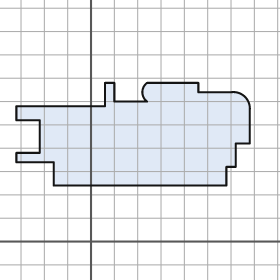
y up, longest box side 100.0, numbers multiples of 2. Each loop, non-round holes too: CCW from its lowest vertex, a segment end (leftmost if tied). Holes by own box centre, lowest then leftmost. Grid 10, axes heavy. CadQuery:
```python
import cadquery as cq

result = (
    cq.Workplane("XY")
    .moveTo(-16.0, 24.0)
    .lineTo(58.0, 24.0)
    .lineTo(58.0, 32.0)
    .lineTo(62.0, 32.0)
    .lineTo(62.0, 42.0)
    .lineTo(68.0, 42.0)
    .lineTo(68.0, 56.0)
    .threePointArc((66.0, 62.0), (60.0, 64.0))
    .lineTo(46.0, 64.0)
    .lineTo(46.0, 68.0)
    .lineTo(24.0, 68.0)
    .threePointArc((22.0, 64.0), (24.0, 60.0))
    .lineTo(10.0, 60.0)
    .lineTo(10.0, 68.0)
    .lineTo(6.0, 68.0)
    .lineTo(6.0, 58.0)
    .lineTo(-32.0, 58.0)
    .lineTo(-32.0, 52.0)
    .lineTo(-22.0, 52.0)
    .lineTo(-22.0, 38.0)
    .lineTo(-32.0, 38.0)
    .lineTo(-32.0, 34.0)
    .lineTo(-16.0, 34.0)
    .close()
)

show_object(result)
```